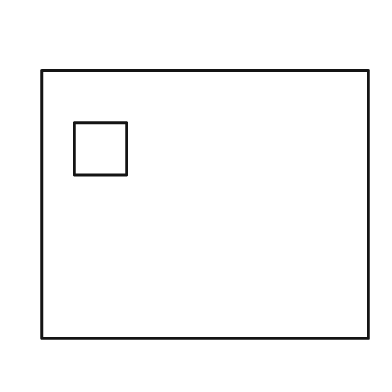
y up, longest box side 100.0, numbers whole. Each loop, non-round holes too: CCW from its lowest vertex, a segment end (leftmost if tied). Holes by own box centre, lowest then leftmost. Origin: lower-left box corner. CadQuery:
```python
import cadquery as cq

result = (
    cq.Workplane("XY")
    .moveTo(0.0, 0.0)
    .lineTo(100.0, 0.0)
    .lineTo(100.0, 82.0)
    .lineTo(0.0, 82.0)
    .close()
    .moveTo(10.0, 50.0)
    .lineTo(26.0, 50.0)
    .lineTo(26.0, 66.0)
    .lineTo(10.0, 66.0)
    .close()
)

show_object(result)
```